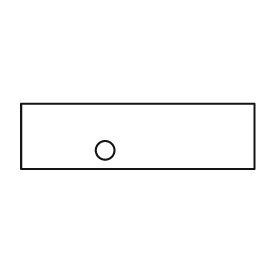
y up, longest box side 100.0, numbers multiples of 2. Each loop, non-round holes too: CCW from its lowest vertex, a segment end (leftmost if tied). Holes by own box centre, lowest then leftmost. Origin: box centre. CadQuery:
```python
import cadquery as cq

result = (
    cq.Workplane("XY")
    .moveTo(-50.0, -14.0)
    .lineTo(50.0, -14.0)
    .lineTo(50.0, 14.0)
    .lineTo(-50.0, 14.0)
    .close()
    .moveTo(-14.0, -6.0)
    .circle(4.0)
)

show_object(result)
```